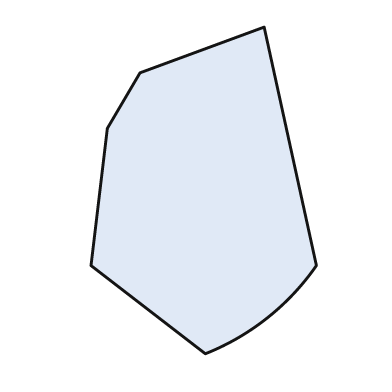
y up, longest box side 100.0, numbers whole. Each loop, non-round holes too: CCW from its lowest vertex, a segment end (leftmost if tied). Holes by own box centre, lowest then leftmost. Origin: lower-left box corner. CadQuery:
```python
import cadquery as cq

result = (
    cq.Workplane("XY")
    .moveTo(35.0, 0.0)
    .threePointArc((54.0, 11.0), (69.0, 27.0))
    .lineTo(53.0, 100.0)
    .lineTo(15.0, 86.0)
    .lineTo(5.0, 69.0)
    .lineTo(0.0, 27.0)
    .close()
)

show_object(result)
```